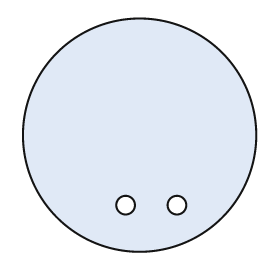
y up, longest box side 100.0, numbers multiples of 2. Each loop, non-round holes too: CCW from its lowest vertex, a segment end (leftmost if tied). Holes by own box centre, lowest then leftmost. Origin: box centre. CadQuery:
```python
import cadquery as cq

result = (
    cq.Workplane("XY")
    .moveTo(0.0, 0.0)
    .circle(50.0)
    .moveTo(-6.0, -30.0)
    .circle(4.0)
    .moveTo(16.0, -30.0)
    .circle(4.0)
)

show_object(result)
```